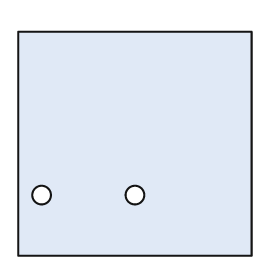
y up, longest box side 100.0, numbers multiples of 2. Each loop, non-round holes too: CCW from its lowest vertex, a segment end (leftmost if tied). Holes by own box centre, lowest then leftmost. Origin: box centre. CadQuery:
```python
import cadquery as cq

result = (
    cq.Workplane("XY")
    .moveTo(-50.0, -48.0)
    .lineTo(50.0, -48.0)
    .lineTo(50.0, 48.0)
    .lineTo(-50.0, 48.0)
    .close()
    .moveTo(-40.0, -22.0)
    .circle(4.0)
    .moveTo(0.0, -22.0)
    .circle(4.0)
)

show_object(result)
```